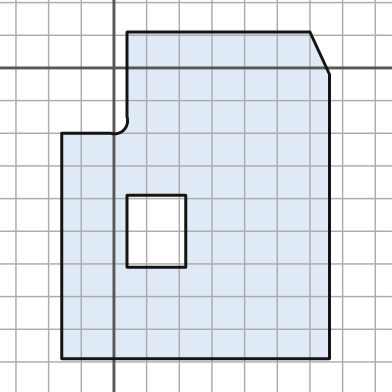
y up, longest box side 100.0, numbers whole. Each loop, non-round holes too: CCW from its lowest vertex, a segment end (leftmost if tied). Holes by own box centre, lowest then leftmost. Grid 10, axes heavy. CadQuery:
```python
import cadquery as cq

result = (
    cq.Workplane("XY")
    .moveTo(-16.0, -89.0)
    .lineTo(66.0, -89.0)
    .lineTo(66.0, -2.0)
    .lineTo(60.0, 11.0)
    .lineTo(4.0, 11.0)
    .lineTo(4.0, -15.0)
    .threePointArc((3.0, -19.0), (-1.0, -20.0))
    .lineTo(-16.0, -20.0)
    .close()
    .moveTo(4.0, -61.0)
    .lineTo(22.0, -61.0)
    .lineTo(22.0, -39.0)
    .lineTo(4.0, -39.0)
    .close()
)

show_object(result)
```